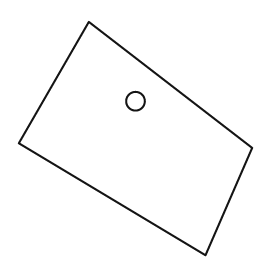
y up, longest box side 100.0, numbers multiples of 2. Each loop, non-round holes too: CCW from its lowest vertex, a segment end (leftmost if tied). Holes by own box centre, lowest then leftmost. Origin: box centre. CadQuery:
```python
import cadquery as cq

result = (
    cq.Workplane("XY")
    .moveTo(30.0, -50.0)
    .lineTo(50.0, -4.0)
    .lineTo(-20.0, 50.0)
    .lineTo(-50.0, -2.0)
    .close()
    .moveTo(0.0, 16.0)
    .circle(4.0)
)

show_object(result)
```